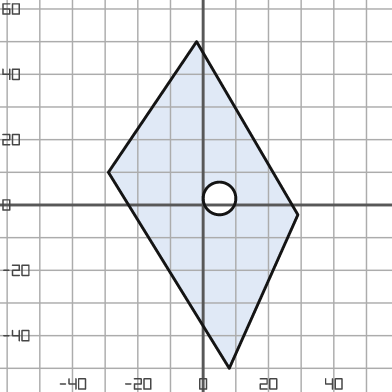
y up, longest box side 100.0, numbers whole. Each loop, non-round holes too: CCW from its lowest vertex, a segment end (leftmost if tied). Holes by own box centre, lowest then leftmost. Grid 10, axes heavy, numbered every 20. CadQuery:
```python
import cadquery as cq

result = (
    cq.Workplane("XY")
    .moveTo(8.0, -50.0)
    .lineTo(29.0, -3.0)
    .lineTo(-2.0, 50.0)
    .lineTo(-29.0, 10.0)
    .close()
    .moveTo(5.0, 2.0)
    .circle(5.0)
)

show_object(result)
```